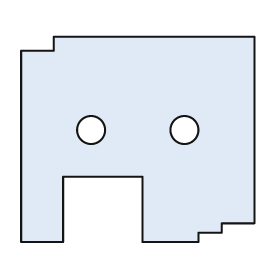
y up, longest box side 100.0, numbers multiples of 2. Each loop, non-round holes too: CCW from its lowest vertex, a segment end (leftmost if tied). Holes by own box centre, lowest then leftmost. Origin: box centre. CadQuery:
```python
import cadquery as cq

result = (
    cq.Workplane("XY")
    .moveTo(-50.0, -44.0)
    .lineTo(-32.0, -44.0)
    .lineTo(-32.0, -16.0)
    .lineTo(2.0, -16.0)
    .lineTo(2.0, -44.0)
    .lineTo(26.0, -44.0)
    .lineTo(26.0, -40.0)
    .lineTo(36.0, -40.0)
    .lineTo(36.0, -36.0)
    .lineTo(50.0, -36.0)
    .lineTo(50.0, 44.0)
    .lineTo(-36.0, 44.0)
    .lineTo(-36.0, 38.0)
    .lineTo(-50.0, 38.0)
    .close()
    .moveTo(-20.0, 4.0)
    .circle(6.0)
    .moveTo(20.0, 4.0)
    .circle(6.0)
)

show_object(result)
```